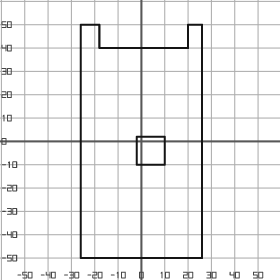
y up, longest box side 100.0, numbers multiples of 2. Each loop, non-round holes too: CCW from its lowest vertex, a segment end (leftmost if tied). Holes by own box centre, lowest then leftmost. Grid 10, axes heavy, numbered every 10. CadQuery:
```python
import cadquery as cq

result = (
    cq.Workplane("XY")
    .moveTo(-26.0, -50.0)
    .lineTo(26.0, -50.0)
    .lineTo(26.0, 50.0)
    .lineTo(20.0, 50.0)
    .lineTo(20.0, 40.0)
    .lineTo(-18.0, 40.0)
    .lineTo(-18.0, 50.0)
    .lineTo(-26.0, 50.0)
    .close()
    .moveTo(-2.0, -10.0)
    .lineTo(10.0, -10.0)
    .lineTo(10.0, 2.0)
    .lineTo(-2.0, 2.0)
    .close()
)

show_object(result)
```